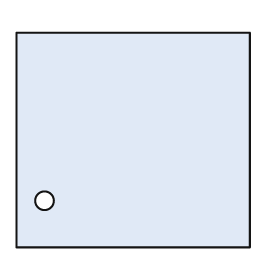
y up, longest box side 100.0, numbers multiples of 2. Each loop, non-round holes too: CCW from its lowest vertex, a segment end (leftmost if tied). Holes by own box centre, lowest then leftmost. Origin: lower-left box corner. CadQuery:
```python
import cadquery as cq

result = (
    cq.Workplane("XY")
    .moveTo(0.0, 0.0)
    .lineTo(100.0, 0.0)
    .lineTo(100.0, 92.0)
    .lineTo(0.0, 92.0)
    .close()
    .moveTo(12.0, 20.0)
    .circle(4.0)
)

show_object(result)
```